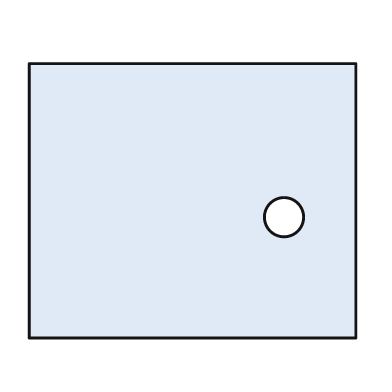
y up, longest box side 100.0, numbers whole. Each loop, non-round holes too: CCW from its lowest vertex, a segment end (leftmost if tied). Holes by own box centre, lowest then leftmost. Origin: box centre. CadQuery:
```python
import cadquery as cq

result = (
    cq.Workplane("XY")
    .moveTo(-50.0, -42.0)
    .lineTo(50.0, -42.0)
    .lineTo(50.0, 42.0)
    .lineTo(-50.0, 42.0)
    .close()
    .moveTo(28.0, -5.0)
    .circle(6.0)
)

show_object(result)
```